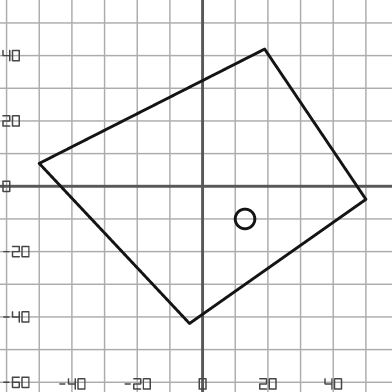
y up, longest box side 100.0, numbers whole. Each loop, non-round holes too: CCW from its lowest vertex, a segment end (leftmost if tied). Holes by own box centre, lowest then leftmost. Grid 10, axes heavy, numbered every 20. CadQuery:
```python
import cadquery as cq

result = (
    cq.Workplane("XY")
    .moveTo(-4.0, -42.0)
    .lineTo(50.0, -4.0)
    .lineTo(19.0, 42.0)
    .lineTo(-50.0, 7.0)
    .close()
    .moveTo(13.0, -10.0)
    .circle(3.0)
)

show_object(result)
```